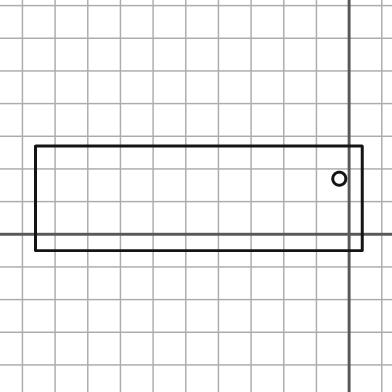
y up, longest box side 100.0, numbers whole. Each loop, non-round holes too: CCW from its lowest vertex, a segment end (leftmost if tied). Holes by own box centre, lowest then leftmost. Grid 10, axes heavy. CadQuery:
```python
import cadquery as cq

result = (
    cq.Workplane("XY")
    .moveTo(-96.0, -5.0)
    .lineTo(4.0, -5.0)
    .lineTo(4.0, 27.0)
    .lineTo(-96.0, 27.0)
    .close()
    .moveTo(-3.0, 17.0)
    .circle(2.0)
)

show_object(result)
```